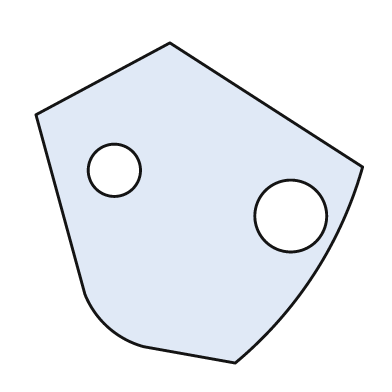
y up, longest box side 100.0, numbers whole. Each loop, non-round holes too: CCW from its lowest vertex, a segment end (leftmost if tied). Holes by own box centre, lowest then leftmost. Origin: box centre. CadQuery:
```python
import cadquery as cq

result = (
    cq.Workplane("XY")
    .moveTo(11.0, -49.0)
    .threePointArc((35.0, -22.0), (50.0, 11.0))
    .lineTo(-9.0, 49.0)
    .lineTo(-50.0, 27.0)
    .lineTo(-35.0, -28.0)
    .threePointArc((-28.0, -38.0), (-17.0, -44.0))
    .close()
    .moveTo(28.0, -4.0)
    .circle(11.0)
    .moveTo(-26.0, 10.0)
    .circle(8.0)
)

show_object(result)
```